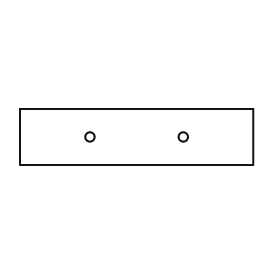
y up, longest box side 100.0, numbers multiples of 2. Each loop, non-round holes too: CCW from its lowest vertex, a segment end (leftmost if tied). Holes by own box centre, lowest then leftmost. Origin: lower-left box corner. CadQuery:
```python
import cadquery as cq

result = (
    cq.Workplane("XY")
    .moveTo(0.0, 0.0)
    .lineTo(100.0, 0.0)
    .lineTo(100.0, 24.0)
    .lineTo(0.0, 24.0)
    .close()
    .moveTo(30.0, 12.0)
    .circle(2.0)
    .moveTo(70.0, 12.0)
    .circle(2.0)
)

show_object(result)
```